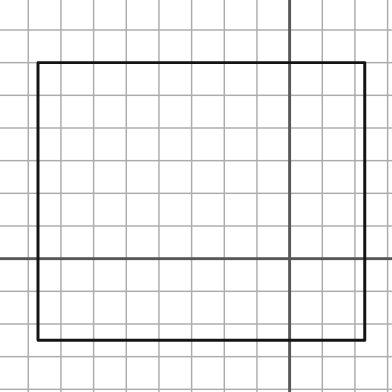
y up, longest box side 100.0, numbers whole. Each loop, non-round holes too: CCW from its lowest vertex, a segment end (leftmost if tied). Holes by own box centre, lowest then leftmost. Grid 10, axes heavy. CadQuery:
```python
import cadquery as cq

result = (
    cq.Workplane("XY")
    .moveTo(-77.0, -25.0)
    .lineTo(23.0, -25.0)
    .lineTo(23.0, 60.0)
    .lineTo(-77.0, 60.0)
    .close()
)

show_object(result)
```